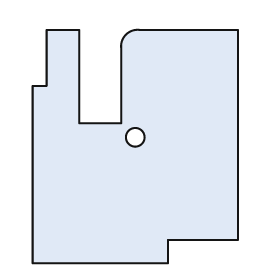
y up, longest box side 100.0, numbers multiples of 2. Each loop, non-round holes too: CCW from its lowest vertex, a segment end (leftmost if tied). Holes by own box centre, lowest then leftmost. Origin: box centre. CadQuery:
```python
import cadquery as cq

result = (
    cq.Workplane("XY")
    .moveTo(-44.0, -50.0)
    .lineTo(14.0, -50.0)
    .lineTo(14.0, -40.0)
    .lineTo(44.0, -40.0)
    .lineTo(44.0, 50.0)
    .lineTo(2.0, 50.0)
    .threePointArc((-4.0, 48.0), (-6.0, 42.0))
    .lineTo(-6.0, 10.0)
    .lineTo(-24.0, 10.0)
    .lineTo(-24.0, 50.0)
    .lineTo(-38.0, 50.0)
    .lineTo(-38.0, 26.0)
    .lineTo(-44.0, 26.0)
    .close()
    .moveTo(0.0, 4.0)
    .circle(4.0)
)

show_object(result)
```